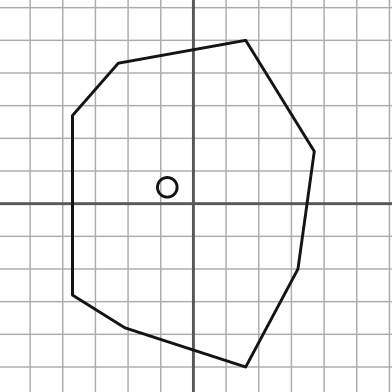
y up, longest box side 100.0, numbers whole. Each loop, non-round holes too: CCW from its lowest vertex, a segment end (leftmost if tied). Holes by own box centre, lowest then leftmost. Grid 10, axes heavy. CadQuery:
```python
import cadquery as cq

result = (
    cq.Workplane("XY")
    .moveTo(16.0, -50.0)
    .lineTo(32.0, -20.0)
    .lineTo(37.0, 16.0)
    .lineTo(16.0, 50.0)
    .lineTo(-23.0, 43.0)
    .lineTo(-37.0, 27.0)
    .lineTo(-37.0, -28.0)
    .lineTo(-21.0, -38.0)
    .close()
    .moveTo(-8.0, 5.0)
    .circle(3.0)
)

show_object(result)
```